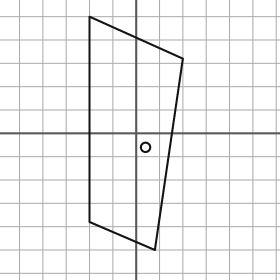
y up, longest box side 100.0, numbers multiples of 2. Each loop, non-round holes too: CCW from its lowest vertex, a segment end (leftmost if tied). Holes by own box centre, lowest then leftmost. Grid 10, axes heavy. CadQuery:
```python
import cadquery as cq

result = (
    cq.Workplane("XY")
    .moveTo(8.0, -50.0)
    .lineTo(20.0, 32.0)
    .lineTo(-20.0, 50.0)
    .lineTo(-20.0, -38.0)
    .close()
    .moveTo(4.0, -6.0)
    .circle(2.0)
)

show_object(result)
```